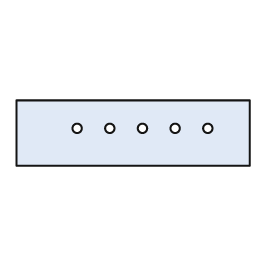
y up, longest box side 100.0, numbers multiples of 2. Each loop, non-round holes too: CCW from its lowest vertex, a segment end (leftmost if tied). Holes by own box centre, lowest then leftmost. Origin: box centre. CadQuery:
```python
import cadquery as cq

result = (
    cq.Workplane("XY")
    .moveTo(-50.0, -14.0)
    .lineTo(50.0, -14.0)
    .lineTo(50.0, 14.0)
    .lineTo(-50.0, 14.0)
    .close()
    .moveTo(-24.0, 2.0)
    .circle(2.0)
    .moveTo(-10.0, 2.0)
    .circle(2.0)
    .moveTo(4.0, 2.0)
    .circle(2.0)
    .moveTo(18.0, 2.0)
    .circle(2.0)
    .moveTo(32.0, 2.0)
    .circle(2.0)
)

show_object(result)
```